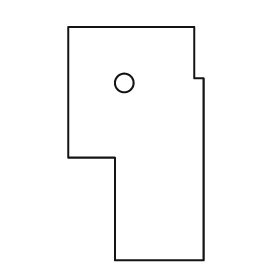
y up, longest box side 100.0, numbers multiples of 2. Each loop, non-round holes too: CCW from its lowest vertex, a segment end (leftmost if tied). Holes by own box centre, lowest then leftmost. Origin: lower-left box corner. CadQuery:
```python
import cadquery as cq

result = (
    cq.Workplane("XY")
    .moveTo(20.0, 0.0)
    .lineTo(58.0, 0.0)
    .lineTo(58.0, 78.0)
    .lineTo(54.0, 78.0)
    .lineTo(54.0, 100.0)
    .lineTo(0.0, 100.0)
    .lineTo(0.0, 44.0)
    .lineTo(20.0, 44.0)
    .close()
    .moveTo(24.0, 76.0)
    .circle(4.0)
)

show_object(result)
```